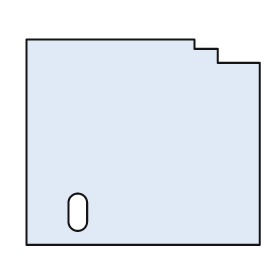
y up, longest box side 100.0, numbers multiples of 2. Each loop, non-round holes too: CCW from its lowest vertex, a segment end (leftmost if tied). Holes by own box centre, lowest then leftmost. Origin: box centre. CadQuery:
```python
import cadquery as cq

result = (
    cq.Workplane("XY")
    .moveTo(-50.0, -44.0)
    .lineTo(50.0, -44.0)
    .lineTo(50.0, 34.0)
    .lineTo(32.0, 34.0)
    .lineTo(32.0, 40.0)
    .lineTo(22.0, 40.0)
    .lineTo(22.0, 44.0)
    .lineTo(-50.0, 44.0)
    .close()
    .moveTo(-32.0, -34.0)
    .threePointArc((-28.0, -38.0), (-24.0, -34.0))
    .lineTo(-24.0, -26.0)
    .threePointArc((-28.0, -22.0), (-32.0, -26.0))
    .close()
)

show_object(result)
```